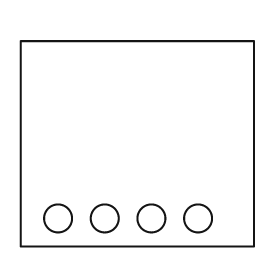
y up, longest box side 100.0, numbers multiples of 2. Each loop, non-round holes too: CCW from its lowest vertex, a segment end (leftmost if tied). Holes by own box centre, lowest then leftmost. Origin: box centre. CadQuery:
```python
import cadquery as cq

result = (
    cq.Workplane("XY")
    .moveTo(-50.0, -44.0)
    .lineTo(50.0, -44.0)
    .lineTo(50.0, 44.0)
    .lineTo(-50.0, 44.0)
    .close()
    .moveTo(-34.0, -32.0)
    .circle(6.0)
    .moveTo(-14.0, -32.0)
    .circle(6.0)
    .moveTo(6.0, -32.0)
    .circle(6.0)
    .moveTo(26.0, -32.0)
    .circle(6.0)
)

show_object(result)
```